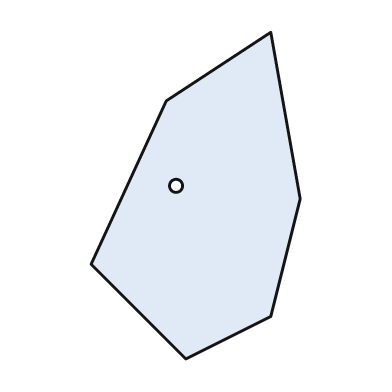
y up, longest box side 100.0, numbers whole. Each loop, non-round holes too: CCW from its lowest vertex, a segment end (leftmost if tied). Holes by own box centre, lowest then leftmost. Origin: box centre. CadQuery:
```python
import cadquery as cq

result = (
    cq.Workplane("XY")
    .moveTo(-3.0, -50.0)
    .lineTo(23.0, -37.0)
    .lineTo(32.0, -1.0)
    .lineTo(23.0, 50.0)
    .lineTo(-9.0, 29.0)
    .lineTo(-32.0, -21.0)
    .close()
    .moveTo(-6.0, 3.0)
    .circle(2.0)
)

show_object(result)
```